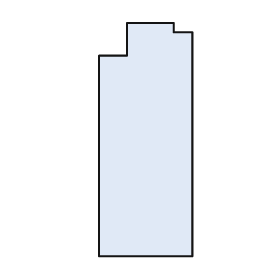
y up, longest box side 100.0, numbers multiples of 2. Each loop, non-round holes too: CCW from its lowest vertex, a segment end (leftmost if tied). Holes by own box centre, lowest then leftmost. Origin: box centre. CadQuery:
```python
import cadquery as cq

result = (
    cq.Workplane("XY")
    .moveTo(-20.0, -50.0)
    .lineTo(20.0, -50.0)
    .lineTo(20.0, 46.0)
    .lineTo(12.0, 46.0)
    .lineTo(12.0, 50.0)
    .lineTo(-8.0, 50.0)
    .lineTo(-8.0, 36.0)
    .lineTo(-20.0, 36.0)
    .close()
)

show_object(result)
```